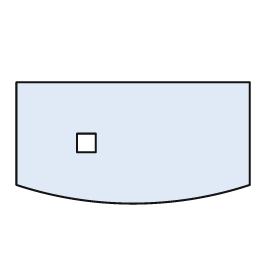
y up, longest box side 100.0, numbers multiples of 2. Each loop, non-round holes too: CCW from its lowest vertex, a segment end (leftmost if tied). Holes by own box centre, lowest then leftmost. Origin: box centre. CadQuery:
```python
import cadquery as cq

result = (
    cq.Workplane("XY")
    .moveTo(-50.0, -18.0)
    .threePointArc((0.0, -26.0), (50.0, -18.0))
    .lineTo(50.0, 26.0)
    .lineTo(-50.0, 26.0)
    .close()
    .moveTo(-24.0, -4.0)
    .lineTo(-16.0, -4.0)
    .lineTo(-16.0, 4.0)
    .lineTo(-24.0, 4.0)
    .close()
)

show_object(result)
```